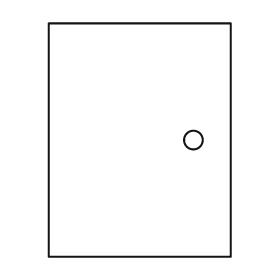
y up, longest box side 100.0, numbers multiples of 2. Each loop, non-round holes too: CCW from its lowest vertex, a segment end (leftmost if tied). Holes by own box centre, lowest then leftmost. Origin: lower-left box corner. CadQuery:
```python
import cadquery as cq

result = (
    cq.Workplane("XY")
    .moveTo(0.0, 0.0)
    .lineTo(78.0, 0.0)
    .lineTo(78.0, 100.0)
    .lineTo(0.0, 100.0)
    .close()
    .moveTo(62.0, 50.0)
    .circle(4.0)
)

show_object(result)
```